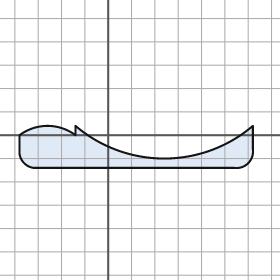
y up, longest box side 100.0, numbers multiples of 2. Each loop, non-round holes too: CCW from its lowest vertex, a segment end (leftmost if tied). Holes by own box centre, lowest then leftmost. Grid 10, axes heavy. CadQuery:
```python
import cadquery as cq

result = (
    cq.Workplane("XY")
    .moveTo(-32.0, -14.0)
    .lineTo(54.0, -14.0)
    .threePointArc((60.0, -12.0), (62.0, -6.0))
    .lineTo(62.0, 4.0)
    .threePointArc((24.0, -10.0), (-14.0, 4.0))
    .lineTo(-14.0, 0.0)
    .threePointArc((-26.0, 4.0), (-38.0, 0.0))
    .lineTo(-38.0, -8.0)
    .threePointArc((-36.0, -12.0), (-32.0, -14.0))
    .close()
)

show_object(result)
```